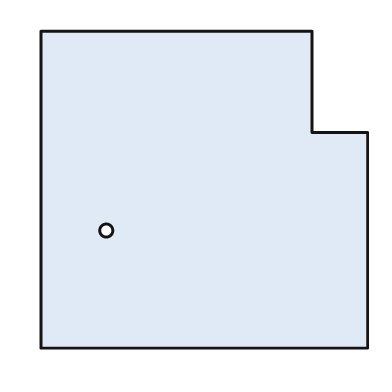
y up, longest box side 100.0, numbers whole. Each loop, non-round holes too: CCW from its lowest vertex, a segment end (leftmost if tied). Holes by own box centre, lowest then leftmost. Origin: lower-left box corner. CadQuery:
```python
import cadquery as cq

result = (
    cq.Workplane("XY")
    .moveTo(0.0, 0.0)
    .lineTo(100.0, 0.0)
    .lineTo(100.0, 66.0)
    .lineTo(83.0, 66.0)
    .lineTo(83.0, 97.0)
    .lineTo(0.0, 97.0)
    .close()
    .moveTo(20.0, 36.0)
    .circle(2.0)
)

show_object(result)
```